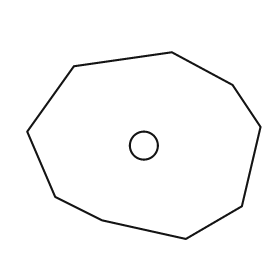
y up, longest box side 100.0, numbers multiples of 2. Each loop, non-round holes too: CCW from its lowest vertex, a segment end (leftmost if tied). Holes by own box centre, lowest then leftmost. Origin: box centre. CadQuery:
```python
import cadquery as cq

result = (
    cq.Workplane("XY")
    .moveTo(18.0, -40.0)
    .lineTo(42.0, -26.0)
    .lineTo(50.0, 8.0)
    .lineTo(38.0, 26.0)
    .lineTo(12.0, 40.0)
    .lineTo(-30.0, 34.0)
    .lineTo(-50.0, 6.0)
    .lineTo(-38.0, -22.0)
    .lineTo(-18.0, -32.0)
    .close()
    .moveTo(0.0, 0.0)
    .circle(6.0)
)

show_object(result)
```